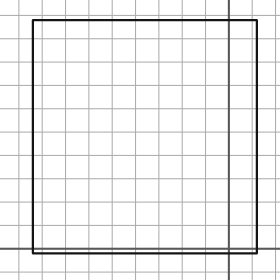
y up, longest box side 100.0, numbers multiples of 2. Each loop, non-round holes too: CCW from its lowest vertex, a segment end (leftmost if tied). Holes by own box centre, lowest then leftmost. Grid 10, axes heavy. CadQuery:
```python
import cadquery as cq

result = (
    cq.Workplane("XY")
    .moveTo(-84.0, -2.0)
    .lineTo(12.0, -2.0)
    .lineTo(12.0, 98.0)
    .lineTo(-84.0, 98.0)
    .close()
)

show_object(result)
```